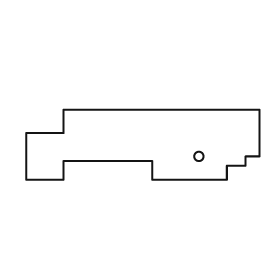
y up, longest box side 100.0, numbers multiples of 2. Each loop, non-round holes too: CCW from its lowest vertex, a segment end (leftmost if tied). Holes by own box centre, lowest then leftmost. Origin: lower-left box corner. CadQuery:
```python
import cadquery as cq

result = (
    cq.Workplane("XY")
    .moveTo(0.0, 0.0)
    .lineTo(16.0, 0.0)
    .lineTo(16.0, 8.0)
    .lineTo(54.0, 8.0)
    .lineTo(54.0, 0.0)
    .lineTo(86.0, 0.0)
    .lineTo(86.0, 6.0)
    .lineTo(94.0, 6.0)
    .lineTo(94.0, 10.0)
    .lineTo(100.0, 10.0)
    .lineTo(100.0, 30.0)
    .lineTo(16.0, 30.0)
    .lineTo(16.0, 20.0)
    .lineTo(0.0, 20.0)
    .close()
    .moveTo(74.0, 10.0)
    .circle(2.0)
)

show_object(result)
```